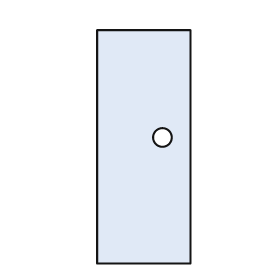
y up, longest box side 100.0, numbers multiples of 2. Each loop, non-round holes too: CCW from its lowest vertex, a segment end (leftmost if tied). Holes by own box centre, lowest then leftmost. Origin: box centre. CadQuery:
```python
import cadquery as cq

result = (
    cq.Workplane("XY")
    .moveTo(-20.0, -50.0)
    .lineTo(20.0, -50.0)
    .lineTo(20.0, 50.0)
    .lineTo(-20.0, 50.0)
    .close()
    .moveTo(8.0, 4.0)
    .circle(4.0)
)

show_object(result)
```